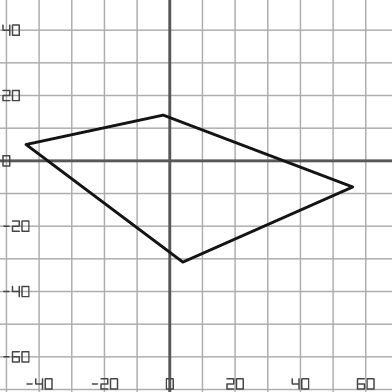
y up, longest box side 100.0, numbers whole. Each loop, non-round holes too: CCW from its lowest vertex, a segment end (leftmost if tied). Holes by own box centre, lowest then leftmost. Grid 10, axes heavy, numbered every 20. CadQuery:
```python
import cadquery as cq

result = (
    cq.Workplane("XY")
    .moveTo(4.0, -31.0)
    .lineTo(56.0, -8.0)
    .lineTo(-2.0, 14.0)
    .lineTo(-44.0, 5.0)
    .close()
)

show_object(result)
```